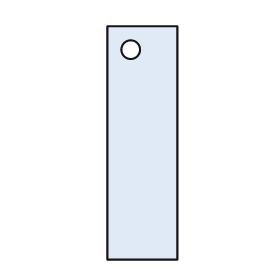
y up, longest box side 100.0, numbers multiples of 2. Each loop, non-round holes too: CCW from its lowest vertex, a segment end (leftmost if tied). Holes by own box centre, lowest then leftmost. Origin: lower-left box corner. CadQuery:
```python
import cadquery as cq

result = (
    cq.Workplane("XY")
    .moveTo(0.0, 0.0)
    .lineTo(30.0, 0.0)
    .lineTo(30.0, 100.0)
    .lineTo(0.0, 100.0)
    .close()
    .moveTo(10.0, 90.0)
    .circle(4.0)
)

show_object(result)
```